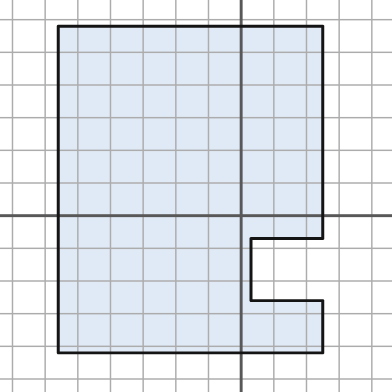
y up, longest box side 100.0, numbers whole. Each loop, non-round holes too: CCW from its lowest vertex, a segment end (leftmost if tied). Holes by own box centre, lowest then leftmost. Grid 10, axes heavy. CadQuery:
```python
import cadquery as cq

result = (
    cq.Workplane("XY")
    .moveTo(-56.0, -42.0)
    .lineTo(25.0, -42.0)
    .lineTo(25.0, -26.0)
    .lineTo(3.0, -26.0)
    .lineTo(3.0, -7.0)
    .lineTo(25.0, -7.0)
    .lineTo(25.0, 58.0)
    .lineTo(-56.0, 58.0)
    .close()
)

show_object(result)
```